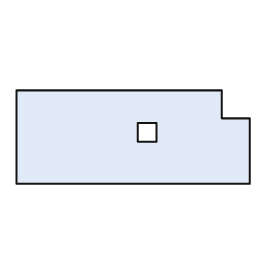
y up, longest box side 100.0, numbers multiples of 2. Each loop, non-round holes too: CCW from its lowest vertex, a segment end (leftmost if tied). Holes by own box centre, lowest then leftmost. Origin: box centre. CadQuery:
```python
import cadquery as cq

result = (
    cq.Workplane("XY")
    .moveTo(-50.0, -20.0)
    .lineTo(50.0, -20.0)
    .lineTo(50.0, 8.0)
    .lineTo(38.0, 8.0)
    .lineTo(38.0, 20.0)
    .lineTo(-50.0, 20.0)
    .close()
    .moveTo(2.0, -2.0)
    .lineTo(10.0, -2.0)
    .lineTo(10.0, 6.0)
    .lineTo(2.0, 6.0)
    .close()
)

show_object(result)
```